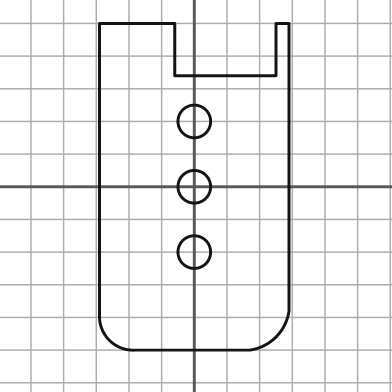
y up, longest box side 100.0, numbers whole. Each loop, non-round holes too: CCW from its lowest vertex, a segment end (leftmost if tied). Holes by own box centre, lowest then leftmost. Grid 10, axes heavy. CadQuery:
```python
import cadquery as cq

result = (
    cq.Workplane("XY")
    .moveTo(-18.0, -50.0)
    .lineTo(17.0, -50.0)
    .threePointArc((25.0, -46.0), (29.0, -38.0))
    .lineTo(29.0, 50.0)
    .lineTo(25.0, 50.0)
    .lineTo(25.0, 34.0)
    .lineTo(-6.0, 34.0)
    .lineTo(-6.0, 50.0)
    .lineTo(-29.0, 50.0)
    .lineTo(-29.0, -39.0)
    .threePointArc((-26.0, -47.0), (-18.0, -50.0))
    .close()
    .moveTo(0.0, -20.0)
    .circle(5.0)
    .moveTo(0.0, 0.0)
    .circle(5.0)
    .moveTo(0.0, 20.0)
    .circle(5.0)
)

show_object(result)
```